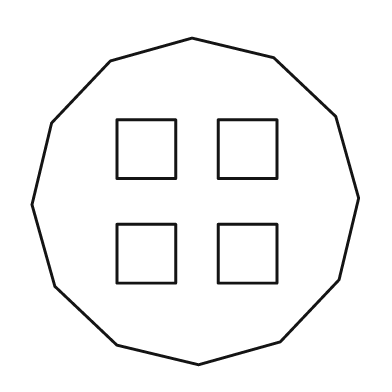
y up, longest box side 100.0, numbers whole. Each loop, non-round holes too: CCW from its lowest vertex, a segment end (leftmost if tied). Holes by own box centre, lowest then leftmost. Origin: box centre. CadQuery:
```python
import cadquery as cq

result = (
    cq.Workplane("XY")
    .moveTo(1.0, -50.0)
    .lineTo(26.0, -43.0)
    .lineTo(44.0, -24.0)
    .lineTo(50.0, 1.0)
    .lineTo(43.0, 26.0)
    .lineTo(24.0, 44.0)
    .lineTo(-1.0, 50.0)
    .lineTo(-26.0, 43.0)
    .lineTo(-44.0, 24.0)
    .lineTo(-50.0, -1.0)
    .lineTo(-43.0, -26.0)
    .lineTo(-24.0, -44.0)
    .close()
    .moveTo(-24.0, -25.0)
    .lineTo(-6.0, -25.0)
    .lineTo(-6.0, -7.0)
    .lineTo(-24.0, -7.0)
    .close()
    .moveTo(7.0, -25.0)
    .lineTo(25.0, -25.0)
    .lineTo(25.0, -7.0)
    .lineTo(7.0, -7.0)
    .close()
    .moveTo(-24.0, 7.0)
    .lineTo(-6.0, 7.0)
    .lineTo(-6.0, 25.0)
    .lineTo(-24.0, 25.0)
    .close()
    .moveTo(7.0, 7.0)
    .lineTo(25.0, 7.0)
    .lineTo(25.0, 25.0)
    .lineTo(7.0, 25.0)
    .close()
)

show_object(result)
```